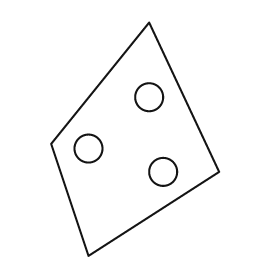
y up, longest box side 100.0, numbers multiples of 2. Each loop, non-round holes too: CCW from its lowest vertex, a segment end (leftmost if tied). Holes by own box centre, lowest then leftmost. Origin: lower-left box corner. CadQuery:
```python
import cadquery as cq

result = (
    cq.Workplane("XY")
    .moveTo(16.0, 0.0)
    .lineTo(72.0, 36.0)
    .lineTo(42.0, 100.0)
    .lineTo(0.0, 48.0)
    .close()
    .moveTo(48.0, 36.0)
    .circle(6.0)
    .moveTo(16.0, 46.0)
    .circle(6.0)
    .moveTo(42.0, 68.0)
    .circle(6.0)
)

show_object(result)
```